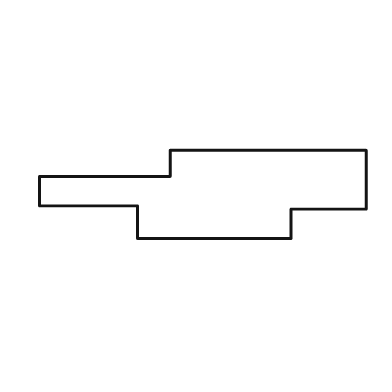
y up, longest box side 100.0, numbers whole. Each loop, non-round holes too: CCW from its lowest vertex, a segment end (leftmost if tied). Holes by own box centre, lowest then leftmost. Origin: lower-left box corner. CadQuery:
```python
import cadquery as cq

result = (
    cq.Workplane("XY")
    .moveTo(30.0, 0.0)
    .lineTo(77.0, 0.0)
    .lineTo(77.0, 9.0)
    .lineTo(100.0, 9.0)
    .lineTo(100.0, 27.0)
    .lineTo(40.0, 27.0)
    .lineTo(40.0, 19.0)
    .lineTo(0.0, 19.0)
    .lineTo(0.0, 10.0)
    .lineTo(30.0, 10.0)
    .close()
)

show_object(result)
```